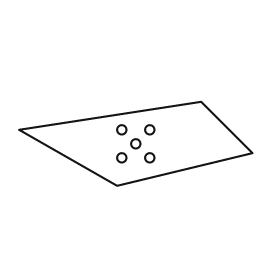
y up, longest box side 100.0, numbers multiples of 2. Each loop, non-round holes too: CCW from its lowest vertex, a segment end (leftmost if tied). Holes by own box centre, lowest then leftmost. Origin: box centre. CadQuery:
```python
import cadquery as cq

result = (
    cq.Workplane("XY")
    .moveTo(-8.0, -18.0)
    .lineTo(50.0, -4.0)
    .lineTo(28.0, 18.0)
    .lineTo(-50.0, 6.0)
    .close()
    .moveTo(-6.0, -6.0)
    .circle(2.0)
    .moveTo(6.0, -6.0)
    .circle(2.0)
    .moveTo(0.0, 0.0)
    .circle(2.0)
    .moveTo(-6.0, 6.0)
    .circle(2.0)
    .moveTo(6.0, 6.0)
    .circle(2.0)
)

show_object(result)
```